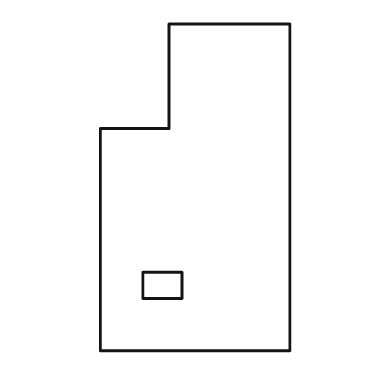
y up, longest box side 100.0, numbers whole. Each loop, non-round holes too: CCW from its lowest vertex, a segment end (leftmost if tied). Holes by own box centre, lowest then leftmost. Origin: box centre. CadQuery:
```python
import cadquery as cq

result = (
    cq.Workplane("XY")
    .moveTo(-29.0, -50.0)
    .lineTo(29.0, -50.0)
    .lineTo(29.0, 50.0)
    .lineTo(-8.0, 50.0)
    .lineTo(-8.0, 18.0)
    .lineTo(-29.0, 18.0)
    .close()
    .moveTo(-16.0, -34.0)
    .lineTo(-4.0, -34.0)
    .lineTo(-4.0, -26.0)
    .lineTo(-16.0, -26.0)
    .close()
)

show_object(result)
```